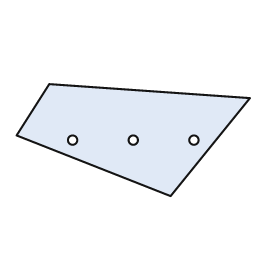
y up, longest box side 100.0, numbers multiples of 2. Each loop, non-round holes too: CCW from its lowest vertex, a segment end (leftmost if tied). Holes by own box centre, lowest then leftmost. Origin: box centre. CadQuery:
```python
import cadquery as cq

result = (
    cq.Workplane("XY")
    .moveTo(16.0, -24.0)
    .lineTo(50.0, 18.0)
    .lineTo(-36.0, 24.0)
    .lineTo(-50.0, 2.0)
    .close()
    .moveTo(-26.0, 0.0)
    .circle(2.0)
    .moveTo(0.0, 0.0)
    .circle(2.0)
    .moveTo(26.0, 0.0)
    .circle(2.0)
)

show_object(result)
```